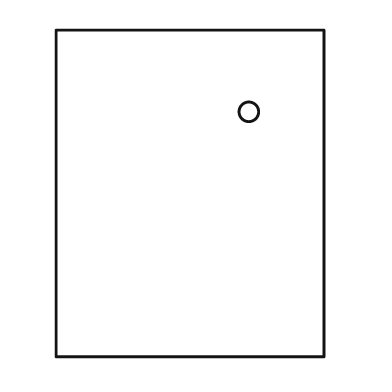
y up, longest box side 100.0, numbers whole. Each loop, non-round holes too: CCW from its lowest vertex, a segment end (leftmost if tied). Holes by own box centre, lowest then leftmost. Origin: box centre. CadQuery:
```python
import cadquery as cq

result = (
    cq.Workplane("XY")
    .moveTo(-41.0, -50.0)
    .lineTo(41.0, -50.0)
    .lineTo(41.0, 50.0)
    .lineTo(-41.0, 50.0)
    .close()
    .moveTo(18.0, 25.0)
    .circle(3.0)
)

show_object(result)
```